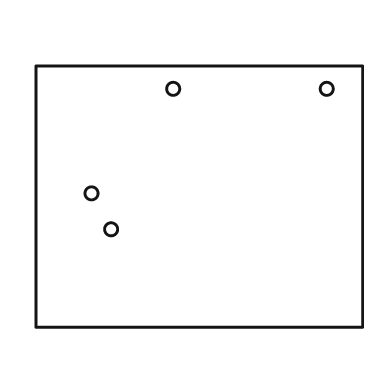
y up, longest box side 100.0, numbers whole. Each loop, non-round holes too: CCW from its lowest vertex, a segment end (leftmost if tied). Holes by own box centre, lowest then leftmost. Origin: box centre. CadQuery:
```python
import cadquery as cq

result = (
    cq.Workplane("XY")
    .moveTo(-50.0, -40.0)
    .lineTo(50.0, -40.0)
    .lineTo(50.0, 40.0)
    .lineTo(-50.0, 40.0)
    .close()
    .moveTo(-27.0, -10.0)
    .circle(2.0)
    .moveTo(-33.0, 1.0)
    .circle(2.0)
    .moveTo(-8.0, 33.0)
    .circle(2.0)
    .moveTo(39.0, 33.0)
    .circle(2.0)
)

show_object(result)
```